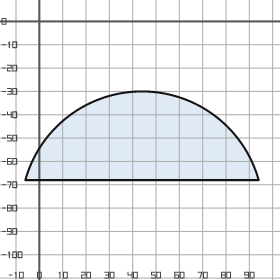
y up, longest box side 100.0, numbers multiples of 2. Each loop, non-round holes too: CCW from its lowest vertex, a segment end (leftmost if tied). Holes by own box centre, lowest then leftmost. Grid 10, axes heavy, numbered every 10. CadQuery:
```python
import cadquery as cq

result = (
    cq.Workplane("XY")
    .moveTo(-6.0, -68.0)
    .lineTo(94.0, -68.0)
    .threePointArc((44.0, -30.0), (-6.0, -68.0))
    .close()
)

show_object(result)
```